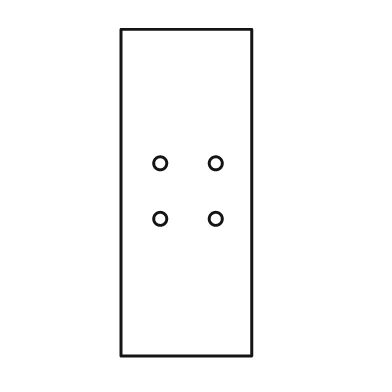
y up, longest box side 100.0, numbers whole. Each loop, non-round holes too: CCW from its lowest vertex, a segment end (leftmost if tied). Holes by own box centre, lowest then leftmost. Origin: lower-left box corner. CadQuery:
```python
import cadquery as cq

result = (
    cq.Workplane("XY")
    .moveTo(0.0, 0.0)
    .lineTo(40.0, 0.0)
    .lineTo(40.0, 100.0)
    .lineTo(0.0, 100.0)
    .close()
    .moveTo(12.0, 42.0)
    .circle(2.0)
    .moveTo(29.0, 42.0)
    .circle(2.0)
    .moveTo(12.0, 59.0)
    .circle(2.0)
    .moveTo(29.0, 59.0)
    .circle(2.0)
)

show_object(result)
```